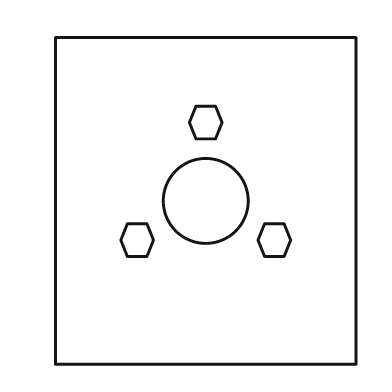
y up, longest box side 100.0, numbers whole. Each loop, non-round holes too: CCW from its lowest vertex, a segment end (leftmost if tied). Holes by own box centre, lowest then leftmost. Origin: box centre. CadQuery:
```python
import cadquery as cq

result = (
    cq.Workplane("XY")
    .moveTo(-46.0, -50.0)
    .lineTo(46.0, -50.0)
    .lineTo(46.0, 50.0)
    .lineTo(-46.0, 50.0)
    .close()
    .moveTo(-24.0, -17.0)
    .lineTo(-18.0, -17.0)
    .lineTo(-16.0, -12.0)
    .lineTo(-18.0, -7.0)
    .lineTo(-24.0, -7.0)
    .lineTo(-26.0, -12.0)
    .close()
    .moveTo(18.0, -17.0)
    .lineTo(24.0, -17.0)
    .lineTo(26.0, -12.0)
    .lineTo(24.0, -7.0)
    .lineTo(18.0, -7.0)
    .lineTo(16.0, -12.0)
    .close()
    .moveTo(0.0, 0.0)
    .circle(13.0)
    .moveTo(-3.0, 19.0)
    .lineTo(3.0, 19.0)
    .lineTo(5.0, 24.0)
    .lineTo(3.0, 29.0)
    .lineTo(-3.0, 29.0)
    .lineTo(-5.0, 24.0)
    .close()
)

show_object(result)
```